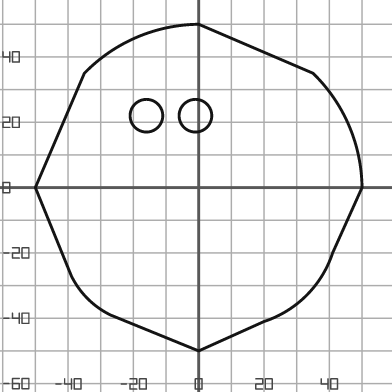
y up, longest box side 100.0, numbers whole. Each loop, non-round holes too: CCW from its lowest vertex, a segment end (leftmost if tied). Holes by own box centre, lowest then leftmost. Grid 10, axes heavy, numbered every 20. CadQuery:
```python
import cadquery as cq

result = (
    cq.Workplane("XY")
    .moveTo(0.0, -50.0)
    .lineTo(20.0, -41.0)
    .threePointArc((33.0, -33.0), (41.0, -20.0))
    .lineTo(50.0, 0.0)
    .threePointArc((46.0, 19.0), (35.0, 35.0))
    .lineTo(0.0, 50.0)
    .threePointArc((-19.0, 46.0), (-35.0, 35.0))
    .lineTo(-50.0, 0.0)
    .lineTo(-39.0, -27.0)
    .threePointArc((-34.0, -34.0), (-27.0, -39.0))
    .close()
    .moveTo(-16.0, 22.0)
    .circle(5.0)
    .moveTo(-1.0, 22.0)
    .circle(5.0)
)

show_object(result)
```